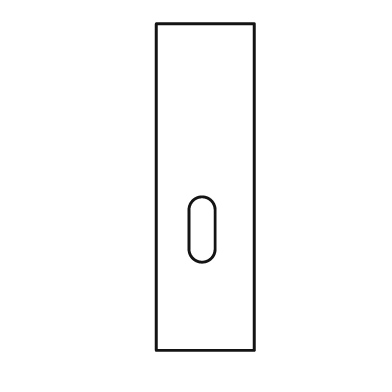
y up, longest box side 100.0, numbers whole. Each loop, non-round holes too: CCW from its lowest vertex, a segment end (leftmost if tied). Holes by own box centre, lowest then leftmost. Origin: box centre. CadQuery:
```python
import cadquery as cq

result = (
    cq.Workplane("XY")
    .moveTo(-15.0, -50.0)
    .lineTo(15.0, -50.0)
    .lineTo(15.0, 50.0)
    .lineTo(-15.0, 50.0)
    .close()
    .moveTo(-5.0, -19.0)
    .threePointArc((-1.0, -23.0), (3.0, -19.0))
    .lineTo(3.0, -7.0)
    .threePointArc((-1.0, -3.0), (-5.0, -7.0))
    .close()
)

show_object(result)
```